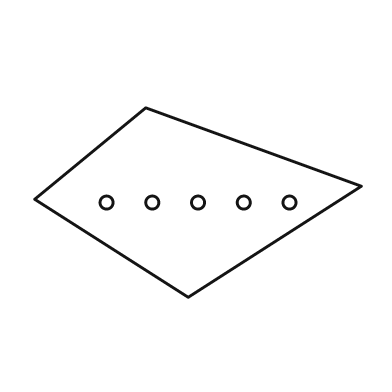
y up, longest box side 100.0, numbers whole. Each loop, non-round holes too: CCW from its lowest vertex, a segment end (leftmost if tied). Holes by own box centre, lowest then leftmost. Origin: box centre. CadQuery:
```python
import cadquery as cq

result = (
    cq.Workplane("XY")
    .moveTo(-3.0, -29.0)
    .lineTo(50.0, 5.0)
    .lineTo(-16.0, 29.0)
    .lineTo(-50.0, 1.0)
    .close()
    .moveTo(-28.0, 0.0)
    .circle(2.0)
    .moveTo(-14.0, 0.0)
    .circle(2.0)
    .moveTo(0.0, 0.0)
    .circle(2.0)
    .moveTo(14.0, 0.0)
    .circle(2.0)
    .moveTo(28.0, 0.0)
    .circle(2.0)
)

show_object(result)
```